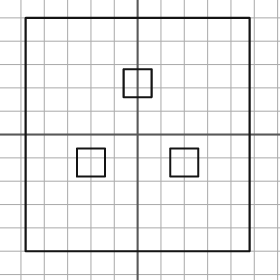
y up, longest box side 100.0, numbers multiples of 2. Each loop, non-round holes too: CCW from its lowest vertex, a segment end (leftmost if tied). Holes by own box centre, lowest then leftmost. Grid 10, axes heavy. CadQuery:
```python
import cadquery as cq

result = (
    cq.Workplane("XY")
    .moveTo(-48.0, -50.0)
    .lineTo(48.0, -50.0)
    .lineTo(48.0, 50.0)
    .lineTo(-48.0, 50.0)
    .close()
    .moveTo(-26.0, -18.0)
    .lineTo(-14.0, -18.0)
    .lineTo(-14.0, -6.0)
    .lineTo(-26.0, -6.0)
    .close()
    .moveTo(14.0, -18.0)
    .lineTo(26.0, -18.0)
    .lineTo(26.0, -6.0)
    .lineTo(14.0, -6.0)
    .close()
    .moveTo(-6.0, 16.0)
    .lineTo(6.0, 16.0)
    .lineTo(6.0, 28.0)
    .lineTo(-6.0, 28.0)
    .close()
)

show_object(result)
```